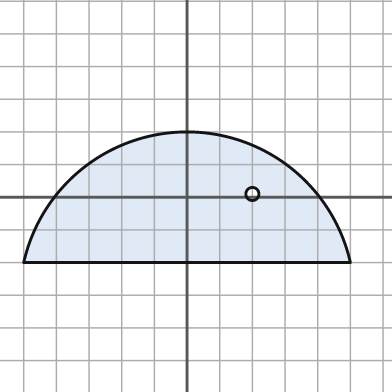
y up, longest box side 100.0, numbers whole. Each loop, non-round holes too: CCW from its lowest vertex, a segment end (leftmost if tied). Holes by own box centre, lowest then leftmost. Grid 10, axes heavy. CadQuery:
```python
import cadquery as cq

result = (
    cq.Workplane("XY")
    .moveTo(-50.0, -20.0)
    .lineTo(50.0, -20.0)
    .threePointArc((0.0, 20.0), (-50.0, -20.0))
    .close()
    .moveTo(20.0, 1.0)
    .circle(2.0)
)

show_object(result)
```